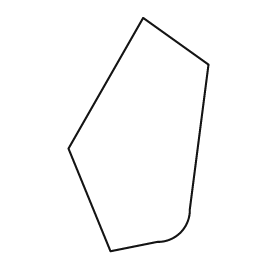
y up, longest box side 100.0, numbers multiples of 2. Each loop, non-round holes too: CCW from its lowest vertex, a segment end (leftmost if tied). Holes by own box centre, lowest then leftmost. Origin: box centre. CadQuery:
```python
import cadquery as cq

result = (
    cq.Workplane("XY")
    .moveTo(-12.0, -50.0)
    .lineTo(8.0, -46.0)
    .threePointArc((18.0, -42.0), (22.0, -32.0))
    .lineTo(30.0, 30.0)
    .lineTo(2.0, 50.0)
    .lineTo(-30.0, -6.0)
    .close()
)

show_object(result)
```